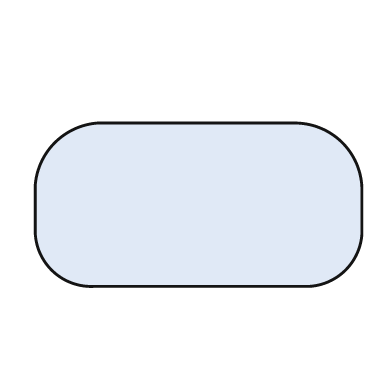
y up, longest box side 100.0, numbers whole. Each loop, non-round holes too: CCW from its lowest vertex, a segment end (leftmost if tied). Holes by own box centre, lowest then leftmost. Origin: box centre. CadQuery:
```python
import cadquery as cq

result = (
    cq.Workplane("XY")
    .moveTo(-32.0, -25.0)
    .lineTo(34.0, -25.0)
    .threePointArc((45.0, -20.0), (50.0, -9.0))
    .lineTo(50.0, 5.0)
    .threePointArc((44.0, 19.0), (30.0, 25.0))
    .lineTo(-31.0, 25.0)
    .threePointArc((-44.0, 19.0), (-50.0, 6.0))
    .lineTo(-50.0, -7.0)
    .threePointArc((-45.0, -20.0), (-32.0, -25.0))
    .close()
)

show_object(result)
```